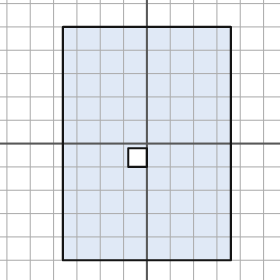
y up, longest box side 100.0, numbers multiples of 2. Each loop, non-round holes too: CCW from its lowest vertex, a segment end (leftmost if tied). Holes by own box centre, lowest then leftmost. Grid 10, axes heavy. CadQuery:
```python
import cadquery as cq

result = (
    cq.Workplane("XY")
    .moveTo(-36.0, -50.0)
    .lineTo(36.0, -50.0)
    .lineTo(36.0, 50.0)
    .lineTo(-36.0, 50.0)
    .close()
    .moveTo(-8.0, -10.0)
    .lineTo(0.0, -10.0)
    .lineTo(0.0, -2.0)
    .lineTo(-8.0, -2.0)
    .close()
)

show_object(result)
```